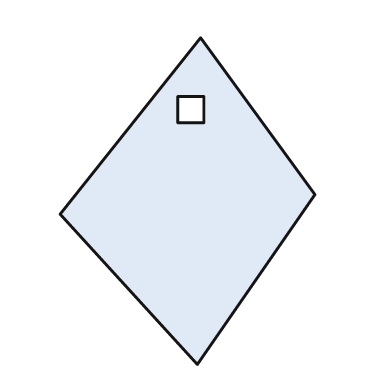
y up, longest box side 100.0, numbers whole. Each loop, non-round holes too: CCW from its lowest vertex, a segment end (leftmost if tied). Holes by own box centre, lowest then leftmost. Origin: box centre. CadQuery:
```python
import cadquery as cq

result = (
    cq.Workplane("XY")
    .moveTo(3.0, -50.0)
    .lineTo(39.0, 2.0)
    .lineTo(4.0, 50.0)
    .lineTo(-39.0, -4.0)
    .close()
    .moveTo(-3.0, 24.0)
    .lineTo(5.0, 24.0)
    .lineTo(5.0, 32.0)
    .lineTo(-3.0, 32.0)
    .close()
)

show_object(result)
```